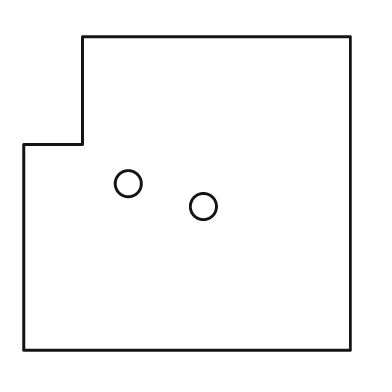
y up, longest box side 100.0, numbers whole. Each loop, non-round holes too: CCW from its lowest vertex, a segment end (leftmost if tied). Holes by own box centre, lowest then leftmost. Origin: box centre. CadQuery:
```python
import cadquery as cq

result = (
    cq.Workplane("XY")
    .moveTo(-50.0, -48.0)
    .lineTo(50.0, -48.0)
    .lineTo(50.0, 48.0)
    .lineTo(-32.0, 48.0)
    .lineTo(-32.0, 15.0)
    .lineTo(-50.0, 15.0)
    .close()
    .moveTo(5.0, -4.0)
    .circle(4.0)
    .moveTo(-18.0, 3.0)
    .circle(4.0)
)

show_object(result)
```